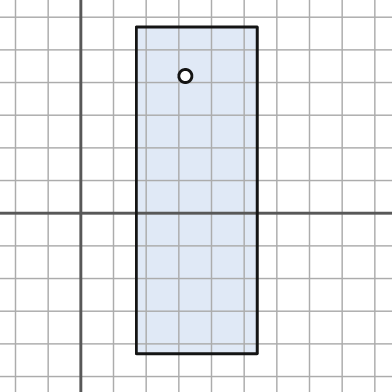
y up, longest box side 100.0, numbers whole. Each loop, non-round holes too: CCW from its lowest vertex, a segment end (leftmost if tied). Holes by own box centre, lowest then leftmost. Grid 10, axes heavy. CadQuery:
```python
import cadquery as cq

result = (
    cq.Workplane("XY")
    .moveTo(17.0, -43.0)
    .lineTo(54.0, -43.0)
    .lineTo(54.0, 57.0)
    .lineTo(17.0, 57.0)
    .close()
    .moveTo(32.0, 42.0)
    .circle(2.0)
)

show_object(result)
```